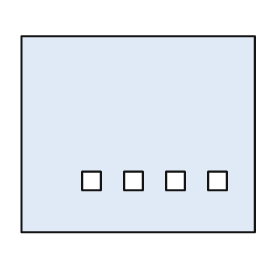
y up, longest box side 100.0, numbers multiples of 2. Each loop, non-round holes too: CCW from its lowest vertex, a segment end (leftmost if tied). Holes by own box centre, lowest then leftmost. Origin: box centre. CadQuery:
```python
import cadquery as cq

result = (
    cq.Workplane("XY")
    .moveTo(-50.0, -42.0)
    .lineTo(50.0, -42.0)
    .lineTo(50.0, 42.0)
    .lineTo(-50.0, 42.0)
    .close()
    .moveTo(-24.0, -24.0)
    .lineTo(-16.0, -24.0)
    .lineTo(-16.0, -16.0)
    .lineTo(-24.0, -16.0)
    .close()
    .moveTo(-6.0, -24.0)
    .lineTo(2.0, -24.0)
    .lineTo(2.0, -16.0)
    .lineTo(-6.0, -16.0)
    .close()
    .moveTo(12.0, -24.0)
    .lineTo(20.0, -24.0)
    .lineTo(20.0, -16.0)
    .lineTo(12.0, -16.0)
    .close()
    .moveTo(30.0, -24.0)
    .lineTo(38.0, -24.0)
    .lineTo(38.0, -16.0)
    .lineTo(30.0, -16.0)
    .close()
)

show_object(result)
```